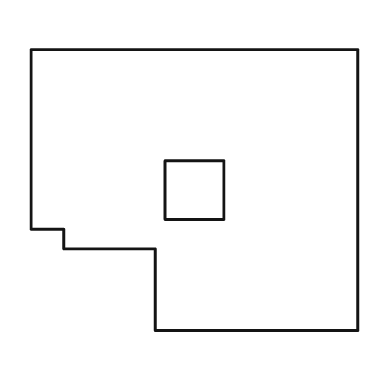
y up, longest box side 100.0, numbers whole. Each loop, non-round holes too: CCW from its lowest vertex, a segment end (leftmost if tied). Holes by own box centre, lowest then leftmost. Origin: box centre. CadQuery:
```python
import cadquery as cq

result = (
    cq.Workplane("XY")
    .moveTo(-12.0, -43.0)
    .lineTo(50.0, -43.0)
    .lineTo(50.0, 43.0)
    .lineTo(-50.0, 43.0)
    .lineTo(-50.0, -12.0)
    .lineTo(-40.0, -12.0)
    .lineTo(-40.0, -18.0)
    .lineTo(-12.0, -18.0)
    .close()
    .moveTo(-9.0, -9.0)
    .lineTo(9.0, -9.0)
    .lineTo(9.0, 9.0)
    .lineTo(-9.0, 9.0)
    .close()
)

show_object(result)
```